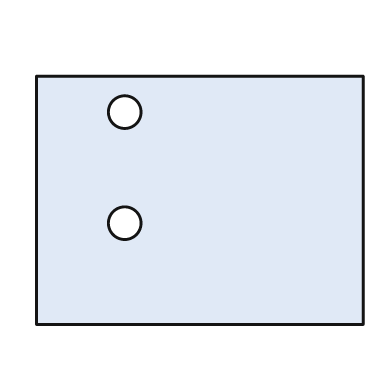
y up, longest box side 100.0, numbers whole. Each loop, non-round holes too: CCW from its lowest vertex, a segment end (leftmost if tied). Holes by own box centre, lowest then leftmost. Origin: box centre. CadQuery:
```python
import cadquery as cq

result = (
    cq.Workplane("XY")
    .moveTo(-50.0, -38.0)
    .lineTo(50.0, -38.0)
    .lineTo(50.0, 38.0)
    .lineTo(-50.0, 38.0)
    .close()
    .moveTo(-23.0, -7.0)
    .circle(5.0)
    .moveTo(-23.0, 27.0)
    .circle(5.0)
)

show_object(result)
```